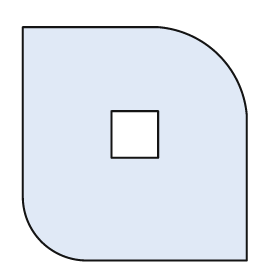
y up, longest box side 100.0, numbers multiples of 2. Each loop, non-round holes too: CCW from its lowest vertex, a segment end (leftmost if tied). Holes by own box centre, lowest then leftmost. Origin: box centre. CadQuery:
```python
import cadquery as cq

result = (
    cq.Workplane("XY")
    .moveTo(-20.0, -50.0)
    .lineTo(48.0, -50.0)
    .lineTo(48.0, 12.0)
    .threePointArc((36.0, 38.0), (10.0, 50.0))
    .lineTo(-48.0, 50.0)
    .lineTo(-48.0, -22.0)
    .threePointArc((-40.0, -42.0), (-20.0, -50.0))
    .close()
    .moveTo(-10.0, -6.0)
    .lineTo(10.0, -6.0)
    .lineTo(10.0, 14.0)
    .lineTo(-10.0, 14.0)
    .close()
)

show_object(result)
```